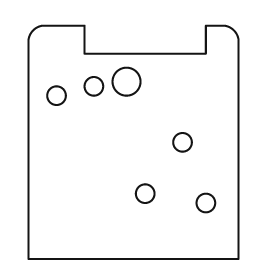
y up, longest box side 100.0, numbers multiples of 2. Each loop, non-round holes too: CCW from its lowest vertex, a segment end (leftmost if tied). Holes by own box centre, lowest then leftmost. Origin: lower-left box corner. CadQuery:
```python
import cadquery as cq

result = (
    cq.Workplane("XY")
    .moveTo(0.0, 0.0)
    .lineTo(90.0, 0.0)
    .lineTo(90.0, 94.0)
    .threePointArc((88.0, 98.0), (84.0, 100.0))
    .lineTo(76.0, 100.0)
    .lineTo(76.0, 88.0)
    .lineTo(24.0, 88.0)
    .lineTo(24.0, 100.0)
    .lineTo(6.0, 100.0)
    .threePointArc((2.0, 98.0), (0.0, 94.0))
    .close()
    .moveTo(76.0, 24.0)
    .circle(4.0)
    .moveTo(50.0, 28.0)
    .circle(4.0)
    .moveTo(66.0, 50.0)
    .circle(4.0)
    .moveTo(12.0, 70.0)
    .circle(4.0)
    .moveTo(28.0, 74.0)
    .circle(4.0)
    .moveTo(42.0, 76.0)
    .circle(6.0)
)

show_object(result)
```